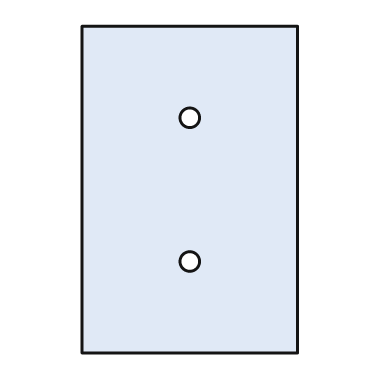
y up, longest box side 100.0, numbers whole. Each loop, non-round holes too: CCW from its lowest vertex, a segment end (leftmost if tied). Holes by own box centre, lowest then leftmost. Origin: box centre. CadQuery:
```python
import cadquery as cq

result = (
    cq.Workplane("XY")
    .moveTo(-33.0, -50.0)
    .lineTo(33.0, -50.0)
    .lineTo(33.0, 50.0)
    .lineTo(-33.0, 50.0)
    .close()
    .moveTo(0.0, -22.0)
    .circle(3.0)
    .moveTo(0.0, 22.0)
    .circle(3.0)
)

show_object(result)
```